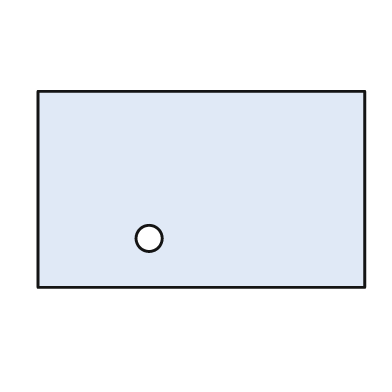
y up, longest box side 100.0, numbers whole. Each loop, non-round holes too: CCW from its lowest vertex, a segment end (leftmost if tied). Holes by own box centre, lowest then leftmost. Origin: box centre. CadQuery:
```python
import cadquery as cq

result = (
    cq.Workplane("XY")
    .moveTo(-50.0, -30.0)
    .lineTo(50.0, -30.0)
    .lineTo(50.0, 30.0)
    .lineTo(-50.0, 30.0)
    .close()
    .moveTo(-16.0, -15.0)
    .circle(4.0)
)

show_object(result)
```